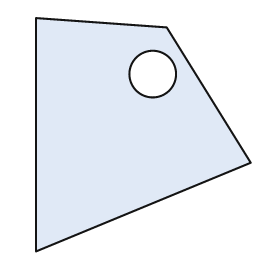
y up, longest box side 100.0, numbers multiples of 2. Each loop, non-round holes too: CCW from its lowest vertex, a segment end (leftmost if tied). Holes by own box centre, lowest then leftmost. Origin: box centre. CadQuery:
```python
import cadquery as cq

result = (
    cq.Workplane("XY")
    .moveTo(-46.0, -50.0)
    .lineTo(46.0, -12.0)
    .lineTo(10.0, 46.0)
    .lineTo(-46.0, 50.0)
    .close()
    .moveTo(4.0, 26.0)
    .circle(10.0)
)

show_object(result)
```